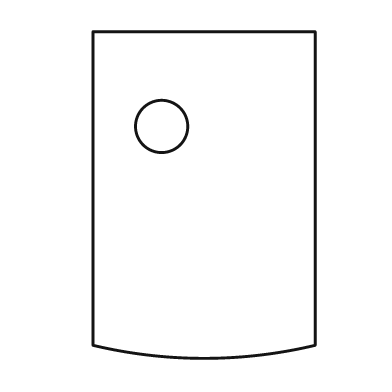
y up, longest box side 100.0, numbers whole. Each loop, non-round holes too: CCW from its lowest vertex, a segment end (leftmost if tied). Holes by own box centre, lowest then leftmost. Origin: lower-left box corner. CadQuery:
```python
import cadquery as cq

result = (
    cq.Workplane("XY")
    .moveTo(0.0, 4.0)
    .threePointArc((34.0, 0.0), (68.0, 4.0))
    .lineTo(68.0, 100.0)
    .lineTo(0.0, 100.0)
    .close()
    .moveTo(21.0, 71.0)
    .circle(8.0)
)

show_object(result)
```